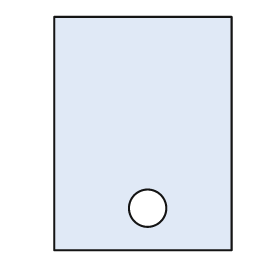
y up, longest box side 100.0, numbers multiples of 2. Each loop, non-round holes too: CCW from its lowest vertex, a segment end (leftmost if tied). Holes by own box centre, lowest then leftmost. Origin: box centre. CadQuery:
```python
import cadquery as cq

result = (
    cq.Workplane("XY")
    .moveTo(-38.0, -50.0)
    .lineTo(38.0, -50.0)
    .lineTo(38.0, 50.0)
    .lineTo(-38.0, 50.0)
    .close()
    .moveTo(2.0, -32.0)
    .circle(8.0)
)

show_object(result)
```